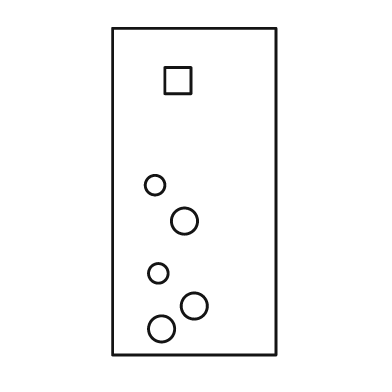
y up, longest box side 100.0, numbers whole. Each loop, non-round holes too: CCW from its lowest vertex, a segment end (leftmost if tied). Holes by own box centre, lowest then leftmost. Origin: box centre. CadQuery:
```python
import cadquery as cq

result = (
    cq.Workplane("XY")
    .moveTo(-25.0, -50.0)
    .lineTo(25.0, -50.0)
    .lineTo(25.0, 50.0)
    .lineTo(-25.0, 50.0)
    .close()
    .moveTo(-10.0, -42.0)
    .circle(4.0)
    .moveTo(0.0, -35.0)
    .circle(4.0)
    .moveTo(-11.0, -25.0)
    .circle(3.0)
    .moveTo(-3.0, -9.0)
    .circle(4.0)
    .moveTo(-12.0, 2.0)
    .circle(3.0)
    .moveTo(-9.0, 30.0)
    .lineTo(-1.0, 30.0)
    .lineTo(-1.0, 38.0)
    .lineTo(-9.0, 38.0)
    .close()
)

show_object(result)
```